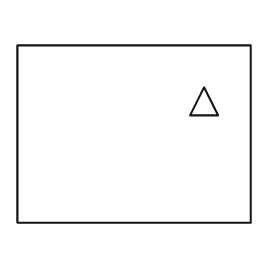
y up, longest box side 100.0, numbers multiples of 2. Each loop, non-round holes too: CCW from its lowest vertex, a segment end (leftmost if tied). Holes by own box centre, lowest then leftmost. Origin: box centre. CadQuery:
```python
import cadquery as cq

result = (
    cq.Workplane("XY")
    .moveTo(-50.0, -38.0)
    .lineTo(50.0, -38.0)
    .lineTo(50.0, 38.0)
    .lineTo(-50.0, 38.0)
    .close()
    .moveTo(24.0, 8.0)
    .lineTo(36.0, 8.0)
    .lineTo(30.0, 20.0)
    .close()
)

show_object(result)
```